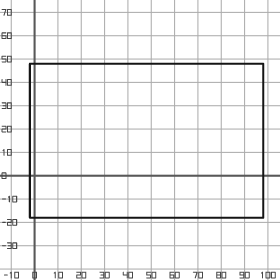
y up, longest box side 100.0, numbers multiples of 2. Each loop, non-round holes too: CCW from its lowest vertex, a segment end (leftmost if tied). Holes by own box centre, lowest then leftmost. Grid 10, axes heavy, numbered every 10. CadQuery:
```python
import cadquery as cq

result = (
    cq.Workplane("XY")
    .moveTo(-2.0, -18.0)
    .lineTo(98.0, -18.0)
    .lineTo(98.0, 48.0)
    .lineTo(-2.0, 48.0)
    .close()
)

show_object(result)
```